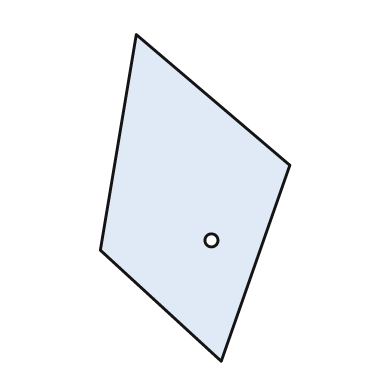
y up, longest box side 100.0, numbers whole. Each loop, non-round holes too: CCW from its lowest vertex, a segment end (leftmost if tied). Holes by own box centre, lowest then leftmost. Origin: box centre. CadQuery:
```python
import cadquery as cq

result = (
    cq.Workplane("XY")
    .moveTo(8.0, -50.0)
    .lineTo(29.0, 10.0)
    .lineTo(-18.0, 50.0)
    .lineTo(-29.0, -16.0)
    .close()
    .moveTo(5.0, -13.0)
    .circle(2.0)
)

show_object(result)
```